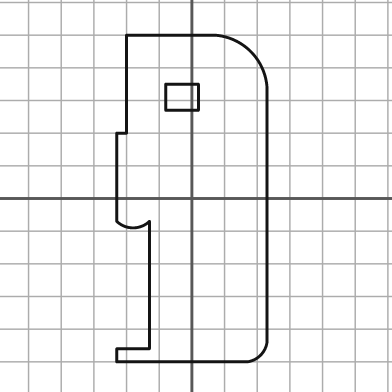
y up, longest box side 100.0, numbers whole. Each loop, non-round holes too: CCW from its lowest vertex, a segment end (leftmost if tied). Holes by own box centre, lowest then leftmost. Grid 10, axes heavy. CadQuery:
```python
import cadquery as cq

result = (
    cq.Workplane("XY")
    .moveTo(-23.0, -50.0)
    .lineTo(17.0, -50.0)
    .threePointArc((21.0, -48.0), (23.0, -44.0))
    .lineTo(23.0, 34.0)
    .threePointArc((18.0, 45.0), (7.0, 50.0))
    .lineTo(-20.0, 50.0)
    .lineTo(-20.0, 20.0)
    .lineTo(-23.0, 20.0)
    .lineTo(-23.0, -7.0)
    .threePointArc((-18.0, -9.0), (-13.0, -7.0))
    .lineTo(-13.0, -46.0)
    .lineTo(-23.0, -46.0)
    .close()
    .moveTo(-8.0, 27.0)
    .lineTo(2.0, 27.0)
    .lineTo(2.0, 35.0)
    .lineTo(-8.0, 35.0)
    .close()
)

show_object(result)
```